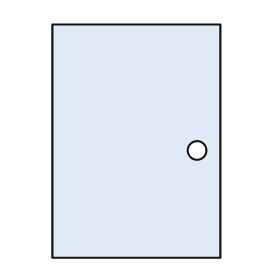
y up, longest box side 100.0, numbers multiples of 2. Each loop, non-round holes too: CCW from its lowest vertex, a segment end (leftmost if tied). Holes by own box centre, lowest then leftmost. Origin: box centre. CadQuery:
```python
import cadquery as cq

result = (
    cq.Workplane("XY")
    .moveTo(-36.0, -50.0)
    .lineTo(36.0, -50.0)
    .lineTo(36.0, 50.0)
    .lineTo(-36.0, 50.0)
    .close()
    .moveTo(26.0, -4.0)
    .circle(4.0)
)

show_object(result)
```